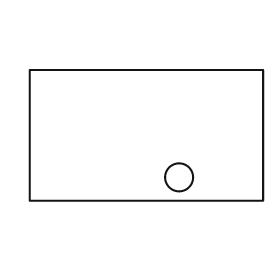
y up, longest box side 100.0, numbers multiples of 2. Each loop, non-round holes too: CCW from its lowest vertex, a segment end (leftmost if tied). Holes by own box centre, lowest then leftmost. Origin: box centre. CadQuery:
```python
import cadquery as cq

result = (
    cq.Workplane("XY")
    .moveTo(-50.0, -28.0)
    .lineTo(50.0, -28.0)
    .lineTo(50.0, 28.0)
    .lineTo(-50.0, 28.0)
    .close()
    .moveTo(14.0, -18.0)
    .circle(6.0)
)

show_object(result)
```